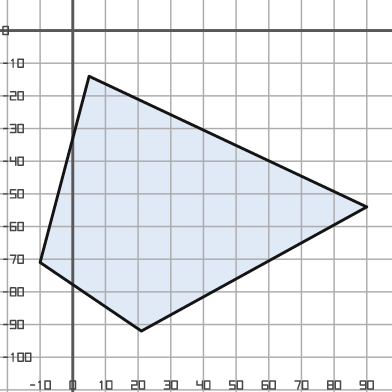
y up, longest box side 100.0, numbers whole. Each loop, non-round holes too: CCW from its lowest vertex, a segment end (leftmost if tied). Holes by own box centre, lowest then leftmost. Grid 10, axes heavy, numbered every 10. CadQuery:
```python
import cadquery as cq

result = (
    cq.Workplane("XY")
    .moveTo(21.0, -92.0)
    .lineTo(90.0, -54.0)
    .lineTo(5.0, -14.0)
    .lineTo(-10.0, -71.0)
    .close()
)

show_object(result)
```